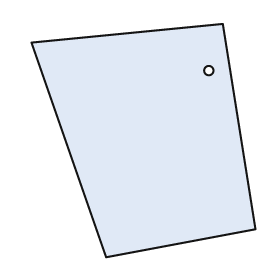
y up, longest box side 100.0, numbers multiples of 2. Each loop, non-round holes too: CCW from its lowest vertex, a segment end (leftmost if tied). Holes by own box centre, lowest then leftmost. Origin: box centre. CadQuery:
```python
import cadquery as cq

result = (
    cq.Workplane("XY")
    .moveTo(-16.0, -50.0)
    .lineTo(48.0, -38.0)
    .lineTo(34.0, 50.0)
    .lineTo(-48.0, 42.0)
    .close()
    .moveTo(28.0, 30.0)
    .circle(2.0)
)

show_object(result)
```